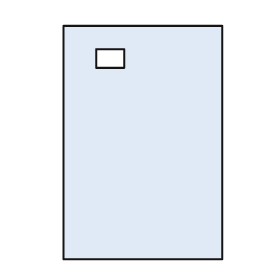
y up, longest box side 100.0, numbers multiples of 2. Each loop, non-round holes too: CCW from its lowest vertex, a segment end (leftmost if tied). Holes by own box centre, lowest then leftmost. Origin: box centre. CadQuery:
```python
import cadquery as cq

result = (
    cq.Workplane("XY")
    .moveTo(-34.0, -50.0)
    .lineTo(34.0, -50.0)
    .lineTo(34.0, 50.0)
    .lineTo(-34.0, 50.0)
    .close()
    .moveTo(-20.0, 32.0)
    .lineTo(-8.0, 32.0)
    .lineTo(-8.0, 40.0)
    .lineTo(-20.0, 40.0)
    .close()
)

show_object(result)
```